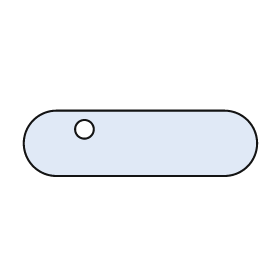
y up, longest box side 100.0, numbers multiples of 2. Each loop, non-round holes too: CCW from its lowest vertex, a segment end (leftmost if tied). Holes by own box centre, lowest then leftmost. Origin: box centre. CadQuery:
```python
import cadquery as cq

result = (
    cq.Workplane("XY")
    .moveTo(-36.0, -14.0)
    .lineTo(36.0, -14.0)
    .threePointArc((50.0, 0.0), (36.0, 14.0))
    .lineTo(-36.0, 14.0)
    .threePointArc((-50.0, 0.0), (-36.0, -14.0))
    .close()
    .moveTo(-24.0, 6.0)
    .circle(4.0)
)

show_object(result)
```